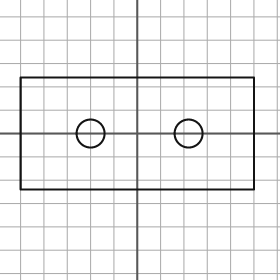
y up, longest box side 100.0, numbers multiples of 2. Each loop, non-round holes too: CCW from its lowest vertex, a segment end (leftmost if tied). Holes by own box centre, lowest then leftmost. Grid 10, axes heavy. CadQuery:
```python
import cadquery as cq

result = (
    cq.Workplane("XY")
    .moveTo(-50.0, -24.0)
    .lineTo(50.0, -24.0)
    .lineTo(50.0, 24.0)
    .lineTo(-50.0, 24.0)
    .close()
    .moveTo(-20.0, 0.0)
    .circle(6.0)
    .moveTo(22.0, 0.0)
    .circle(6.0)
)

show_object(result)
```